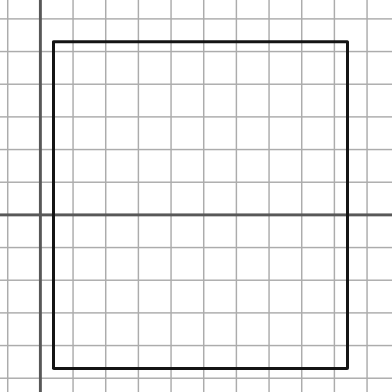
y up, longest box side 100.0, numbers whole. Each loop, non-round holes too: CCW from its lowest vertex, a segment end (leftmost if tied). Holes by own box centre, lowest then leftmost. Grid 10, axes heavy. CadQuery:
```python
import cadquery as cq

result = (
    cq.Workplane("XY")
    .moveTo(4.0, -47.0)
    .lineTo(94.0, -47.0)
    .lineTo(94.0, 53.0)
    .lineTo(4.0, 53.0)
    .close()
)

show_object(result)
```